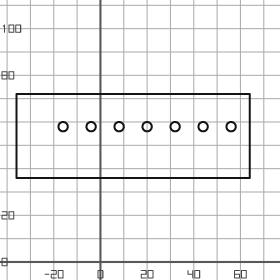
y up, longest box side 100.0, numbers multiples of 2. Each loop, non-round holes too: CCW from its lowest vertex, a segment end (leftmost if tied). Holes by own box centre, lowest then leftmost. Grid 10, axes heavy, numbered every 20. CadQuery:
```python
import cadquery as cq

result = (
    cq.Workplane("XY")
    .moveTo(-36.0, 36.0)
    .lineTo(64.0, 36.0)
    .lineTo(64.0, 72.0)
    .lineTo(-36.0, 72.0)
    .close()
    .moveTo(-16.0, 58.0)
    .circle(2.0)
    .moveTo(-4.0, 58.0)
    .circle(2.0)
    .moveTo(8.0, 58.0)
    .circle(2.0)
    .moveTo(20.0, 58.0)
    .circle(2.0)
    .moveTo(32.0, 58.0)
    .circle(2.0)
    .moveTo(44.0, 58.0)
    .circle(2.0)
    .moveTo(56.0, 58.0)
    .circle(2.0)
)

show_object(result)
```